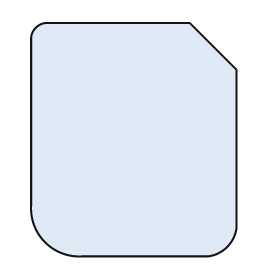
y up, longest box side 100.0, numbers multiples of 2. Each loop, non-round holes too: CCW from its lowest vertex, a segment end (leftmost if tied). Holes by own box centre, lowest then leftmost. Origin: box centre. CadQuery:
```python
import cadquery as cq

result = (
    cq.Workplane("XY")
    .moveTo(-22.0, -50.0)
    .lineTo(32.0, -50.0)
    .threePointArc((40.0, -46.0), (44.0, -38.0))
    .lineTo(44.0, 30.0)
    .lineTo(24.0, 50.0)
    .lineTo(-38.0, 50.0)
    .threePointArc((-42.0, 48.0), (-44.0, 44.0))
    .lineTo(-44.0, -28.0)
    .threePointArc((-38.0, -44.0), (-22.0, -50.0))
    .close()
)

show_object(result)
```